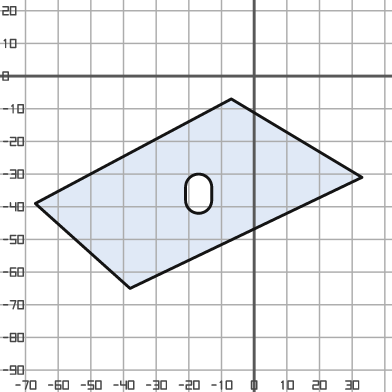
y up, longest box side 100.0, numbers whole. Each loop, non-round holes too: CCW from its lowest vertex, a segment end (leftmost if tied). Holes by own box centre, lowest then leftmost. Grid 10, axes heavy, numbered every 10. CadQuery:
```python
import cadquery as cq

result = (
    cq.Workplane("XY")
    .moveTo(-38.0, -65.0)
    .lineTo(33.0, -31.0)
    .lineTo(-7.0, -7.0)
    .lineTo(-67.0, -39.0)
    .close()
    .moveTo(-21.0, -38.0)
    .threePointArc((-17.0, -42.0), (-13.0, -38.0))
    .lineTo(-13.0, -34.0)
    .threePointArc((-17.0, -30.0), (-21.0, -34.0))
    .close()
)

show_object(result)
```